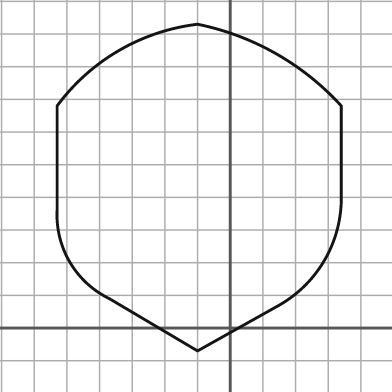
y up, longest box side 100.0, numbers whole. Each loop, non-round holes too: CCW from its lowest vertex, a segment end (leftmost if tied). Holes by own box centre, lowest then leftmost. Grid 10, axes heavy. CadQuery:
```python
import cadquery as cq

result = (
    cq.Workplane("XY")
    .moveTo(-10.0, -7.0)
    .lineTo(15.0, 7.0)
    .threePointArc((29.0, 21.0), (34.0, 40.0))
    .lineTo(34.0, 68.0)
    .threePointArc((14.0, 84.0), (-10.0, 93.0))
    .threePointArc((-34.0, 85.0), (-53.0, 68.0))
    .lineTo(-53.0, 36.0)
    .threePointArc((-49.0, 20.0), (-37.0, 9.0))
    .close()
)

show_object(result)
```